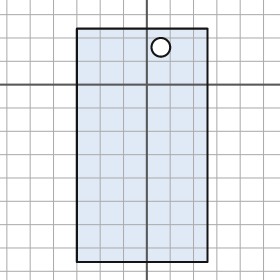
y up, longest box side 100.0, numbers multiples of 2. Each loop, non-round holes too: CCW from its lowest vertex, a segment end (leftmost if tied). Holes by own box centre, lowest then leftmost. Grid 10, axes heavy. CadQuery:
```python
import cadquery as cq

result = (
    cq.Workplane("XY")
    .moveTo(-30.0, -76.0)
    .lineTo(26.0, -76.0)
    .lineTo(26.0, 24.0)
    .lineTo(-30.0, 24.0)
    .close()
    .moveTo(6.0, 16.0)
    .circle(4.0)
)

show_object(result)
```